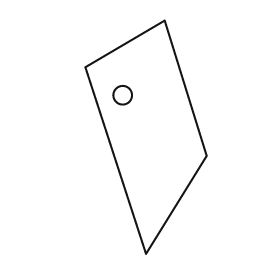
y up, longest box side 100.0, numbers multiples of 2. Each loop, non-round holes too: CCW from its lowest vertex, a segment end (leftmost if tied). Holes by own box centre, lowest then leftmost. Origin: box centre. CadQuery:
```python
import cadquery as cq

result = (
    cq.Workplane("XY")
    .moveTo(0.0, -50.0)
    .lineTo(26.0, -8.0)
    .lineTo(8.0, 50.0)
    .lineTo(-26.0, 30.0)
    .close()
    .moveTo(-10.0, 18.0)
    .circle(4.0)
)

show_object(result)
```